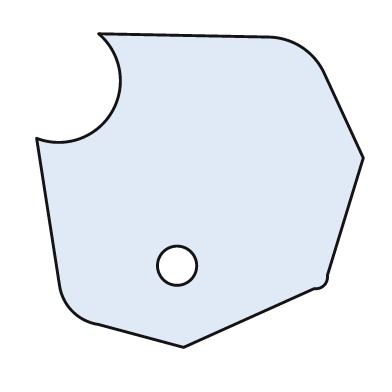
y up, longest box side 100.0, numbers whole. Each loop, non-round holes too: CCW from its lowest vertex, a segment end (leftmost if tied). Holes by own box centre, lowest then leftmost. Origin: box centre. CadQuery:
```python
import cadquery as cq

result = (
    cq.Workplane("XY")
    .moveTo(-5.0, -48.0)
    .lineTo(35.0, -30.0)
    .threePointArc((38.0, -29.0), (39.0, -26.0))
    .lineTo(50.0, 10.0)
    .lineTo(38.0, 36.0)
    .threePointArc((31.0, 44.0), (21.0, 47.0))
    .lineTo(-31.0, 48.0)
    .threePointArc((-27.0, 24.0), (-50.0, 16.0))
    .lineTo(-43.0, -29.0)
    .threePointArc((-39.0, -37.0), (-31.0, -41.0))
    .close()
    .moveTo(-7.0, -23.0)
    .circle(6.0)
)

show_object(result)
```